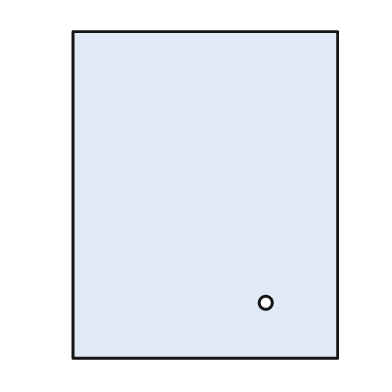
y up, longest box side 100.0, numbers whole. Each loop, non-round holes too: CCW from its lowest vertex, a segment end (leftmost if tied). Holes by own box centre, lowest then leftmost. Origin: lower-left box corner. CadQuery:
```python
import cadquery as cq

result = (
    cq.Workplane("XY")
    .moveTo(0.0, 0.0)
    .lineTo(81.0, 0.0)
    .lineTo(81.0, 100.0)
    .lineTo(0.0, 100.0)
    .close()
    .moveTo(59.0, 17.0)
    .circle(2.0)
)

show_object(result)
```